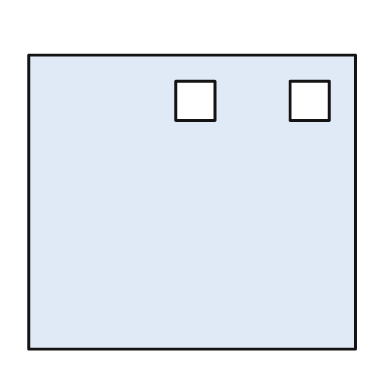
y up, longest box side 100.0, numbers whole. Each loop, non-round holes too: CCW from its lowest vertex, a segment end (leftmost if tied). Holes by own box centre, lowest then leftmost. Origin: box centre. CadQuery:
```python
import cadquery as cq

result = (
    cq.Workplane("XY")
    .moveTo(-50.0, -45.0)
    .lineTo(50.0, -45.0)
    .lineTo(50.0, 45.0)
    .lineTo(-50.0, 45.0)
    .close()
    .moveTo(-5.0, 25.0)
    .lineTo(7.0, 25.0)
    .lineTo(7.0, 37.0)
    .lineTo(-5.0, 37.0)
    .close()
    .moveTo(30.0, 25.0)
    .lineTo(42.0, 25.0)
    .lineTo(42.0, 37.0)
    .lineTo(30.0, 37.0)
    .close()
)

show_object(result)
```